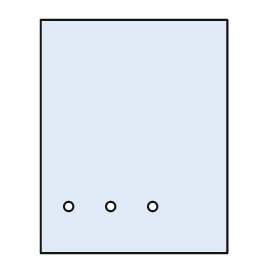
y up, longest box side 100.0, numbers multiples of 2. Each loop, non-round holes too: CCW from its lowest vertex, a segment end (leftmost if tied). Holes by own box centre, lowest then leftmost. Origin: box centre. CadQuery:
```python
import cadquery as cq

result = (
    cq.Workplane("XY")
    .moveTo(-40.0, -50.0)
    .lineTo(40.0, -50.0)
    .lineTo(40.0, 50.0)
    .lineTo(-40.0, 50.0)
    .close()
    .moveTo(-28.0, -30.0)
    .circle(2.0)
    .moveTo(-10.0, -30.0)
    .circle(2.0)
    .moveTo(8.0, -30.0)
    .circle(2.0)
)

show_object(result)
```